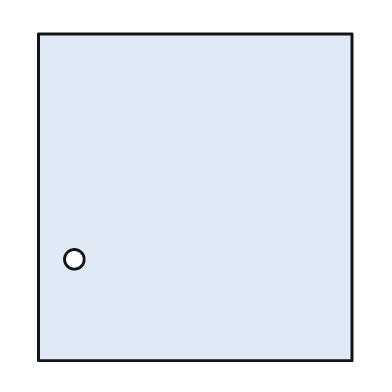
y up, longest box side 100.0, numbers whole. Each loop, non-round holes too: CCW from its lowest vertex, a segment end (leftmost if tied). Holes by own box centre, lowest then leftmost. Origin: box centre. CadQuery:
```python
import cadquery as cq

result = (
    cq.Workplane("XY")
    .moveTo(-48.0, -50.0)
    .lineTo(48.0, -50.0)
    .lineTo(48.0, 50.0)
    .lineTo(-48.0, 50.0)
    .close()
    .moveTo(-37.0, -19.0)
    .circle(3.0)
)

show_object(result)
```